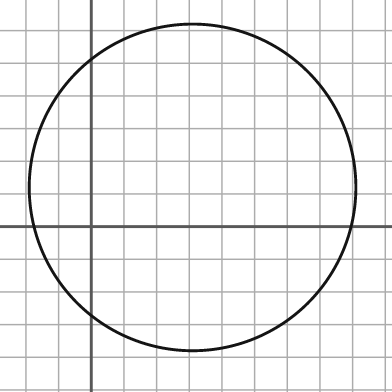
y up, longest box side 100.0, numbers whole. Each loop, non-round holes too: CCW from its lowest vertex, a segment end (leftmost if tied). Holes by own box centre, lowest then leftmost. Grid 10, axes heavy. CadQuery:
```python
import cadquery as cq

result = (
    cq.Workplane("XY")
    .moveTo(31.0, 12.0)
    .circle(50.0)
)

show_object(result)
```